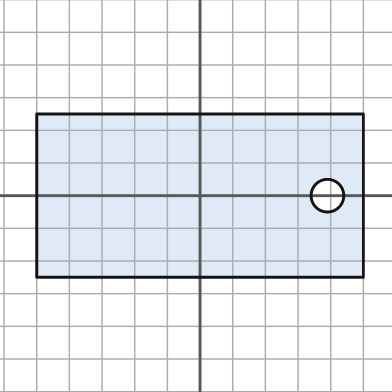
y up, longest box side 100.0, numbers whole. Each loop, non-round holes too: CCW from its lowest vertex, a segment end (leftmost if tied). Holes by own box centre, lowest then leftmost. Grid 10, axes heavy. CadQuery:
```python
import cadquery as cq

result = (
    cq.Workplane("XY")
    .moveTo(-50.0, -25.0)
    .lineTo(50.0, -25.0)
    .lineTo(50.0, 25.0)
    .lineTo(-50.0, 25.0)
    .close()
    .moveTo(39.0, 0.0)
    .circle(5.0)
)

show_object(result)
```